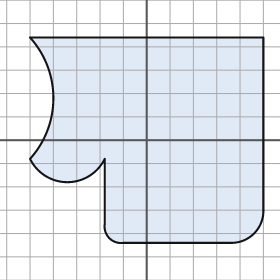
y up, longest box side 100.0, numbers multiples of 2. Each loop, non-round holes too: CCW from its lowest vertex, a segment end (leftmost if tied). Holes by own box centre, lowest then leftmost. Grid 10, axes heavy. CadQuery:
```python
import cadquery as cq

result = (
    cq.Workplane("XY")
    .moveTo(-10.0, -44.0)
    .lineTo(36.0, -44.0)
    .threePointArc((46.0, -40.0), (50.0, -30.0))
    .lineTo(50.0, 44.0)
    .lineTo(-50.0, 44.0)
    .threePointArc((-40.0, 18.0), (-50.0, -8.0))
    .threePointArc((-34.0, -18.0), (-18.0, -8.0))
    .lineTo(-18.0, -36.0)
    .threePointArc((-16.0, -42.0), (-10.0, -44.0))
    .close()
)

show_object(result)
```